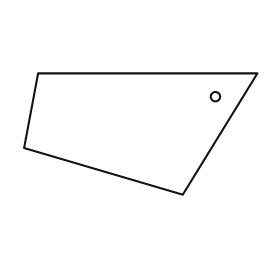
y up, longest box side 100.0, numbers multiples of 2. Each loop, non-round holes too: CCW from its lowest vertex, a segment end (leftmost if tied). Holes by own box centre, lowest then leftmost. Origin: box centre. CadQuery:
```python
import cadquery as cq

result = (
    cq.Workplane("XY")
    .moveTo(18.0, -26.0)
    .lineTo(50.0, 26.0)
    .lineTo(-44.0, 26.0)
    .lineTo(-50.0, -6.0)
    .close()
    .moveTo(32.0, 16.0)
    .circle(2.0)
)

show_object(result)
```